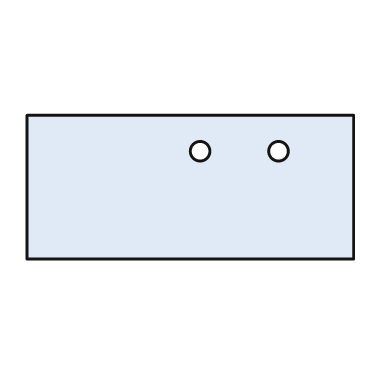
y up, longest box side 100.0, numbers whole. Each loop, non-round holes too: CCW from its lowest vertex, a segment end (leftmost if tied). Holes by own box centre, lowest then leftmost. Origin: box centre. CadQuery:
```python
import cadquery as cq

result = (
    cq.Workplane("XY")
    .moveTo(-50.0, -22.0)
    .lineTo(50.0, -22.0)
    .lineTo(50.0, 22.0)
    .lineTo(-50.0, 22.0)
    .close()
    .moveTo(3.0, 11.0)
    .circle(3.0)
    .moveTo(27.0, 11.0)
    .circle(3.0)
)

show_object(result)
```